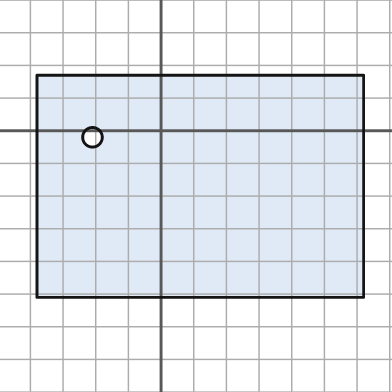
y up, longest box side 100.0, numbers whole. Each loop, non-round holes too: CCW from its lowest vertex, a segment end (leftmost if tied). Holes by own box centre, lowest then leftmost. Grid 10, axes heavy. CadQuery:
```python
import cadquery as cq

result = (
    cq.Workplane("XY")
    .moveTo(-38.0, -51.0)
    .lineTo(62.0, -51.0)
    .lineTo(62.0, 17.0)
    .lineTo(-38.0, 17.0)
    .close()
    .moveTo(-21.0, -2.0)
    .circle(3.0)
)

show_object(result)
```